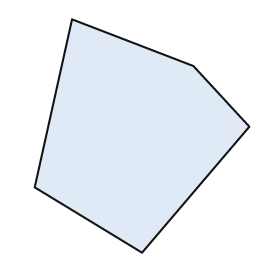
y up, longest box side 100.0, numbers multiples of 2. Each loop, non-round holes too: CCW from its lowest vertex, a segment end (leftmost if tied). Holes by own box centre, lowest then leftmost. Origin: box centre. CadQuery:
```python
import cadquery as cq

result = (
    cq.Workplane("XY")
    .moveTo(0.0, -50.0)
    .lineTo(46.0, 4.0)
    .lineTo(22.0, 30.0)
    .lineTo(-30.0, 50.0)
    .lineTo(-46.0, -22.0)
    .close()
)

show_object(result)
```